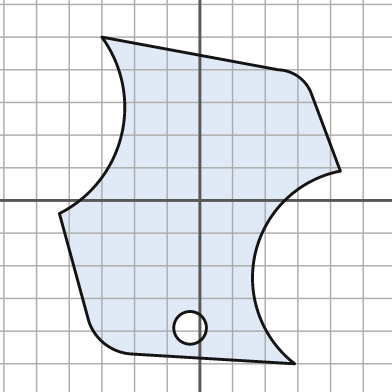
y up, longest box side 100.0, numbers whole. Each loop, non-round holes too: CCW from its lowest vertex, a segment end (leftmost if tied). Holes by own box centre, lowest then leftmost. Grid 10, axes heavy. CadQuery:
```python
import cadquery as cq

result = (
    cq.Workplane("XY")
    .moveTo(29.0, -50.0)
    .threePointArc((17.0, -16.0), (43.0, 9.0))
    .lineTo(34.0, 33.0)
    .threePointArc((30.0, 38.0), (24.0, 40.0))
    .lineTo(-30.0, 50.0)
    .threePointArc((-24.0, 20.0), (-43.0, -4.0))
    .lineTo(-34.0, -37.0)
    .threePointArc((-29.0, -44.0), (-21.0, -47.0))
    .close()
    .moveTo(-3.0, -39.0)
    .circle(5.0)
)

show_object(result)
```